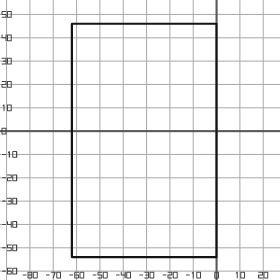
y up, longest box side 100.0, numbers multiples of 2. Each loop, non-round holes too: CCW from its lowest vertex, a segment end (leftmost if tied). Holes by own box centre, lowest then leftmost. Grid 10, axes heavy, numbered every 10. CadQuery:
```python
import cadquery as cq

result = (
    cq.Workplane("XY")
    .moveTo(-62.0, -54.0)
    .lineTo(0.0, -54.0)
    .lineTo(0.0, 46.0)
    .lineTo(-62.0, 46.0)
    .close()
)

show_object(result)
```